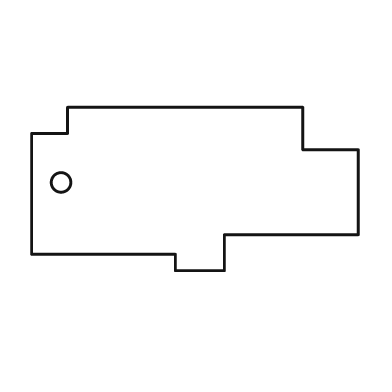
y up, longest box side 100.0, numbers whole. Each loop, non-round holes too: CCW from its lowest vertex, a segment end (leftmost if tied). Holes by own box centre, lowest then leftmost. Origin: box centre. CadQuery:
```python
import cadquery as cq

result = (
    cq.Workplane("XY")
    .moveTo(-6.0, -25.0)
    .lineTo(9.0, -25.0)
    .lineTo(9.0, -14.0)
    .lineTo(50.0, -14.0)
    .lineTo(50.0, 12.0)
    .lineTo(33.0, 12.0)
    .lineTo(33.0, 25.0)
    .lineTo(-39.0, 25.0)
    .lineTo(-39.0, 17.0)
    .lineTo(-50.0, 17.0)
    .lineTo(-50.0, -20.0)
    .lineTo(-6.0, -20.0)
    .close()
    .moveTo(-41.0, 2.0)
    .circle(3.0)
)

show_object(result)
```